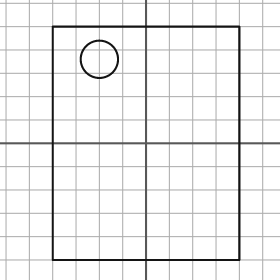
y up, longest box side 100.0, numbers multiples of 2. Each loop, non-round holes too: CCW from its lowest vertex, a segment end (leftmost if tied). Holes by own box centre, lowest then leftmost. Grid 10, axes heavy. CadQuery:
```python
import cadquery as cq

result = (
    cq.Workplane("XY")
    .moveTo(-40.0, -50.0)
    .lineTo(40.0, -50.0)
    .lineTo(40.0, 50.0)
    .lineTo(-40.0, 50.0)
    .close()
    .moveTo(-20.0, 36.0)
    .circle(8.0)
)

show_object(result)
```